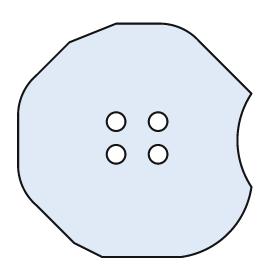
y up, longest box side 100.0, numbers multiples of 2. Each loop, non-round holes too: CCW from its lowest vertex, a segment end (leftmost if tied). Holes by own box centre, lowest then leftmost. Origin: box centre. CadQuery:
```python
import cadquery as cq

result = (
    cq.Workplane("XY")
    .moveTo(-14.0, -50.0)
    .lineTo(20.0, -50.0)
    .threePointArc((40.0, -40.0), (50.0, -20.0))
    .threePointArc((44.0, 0.0), (50.0, 20.0))
    .lineTo(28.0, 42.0)
    .threePointArc((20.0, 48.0), (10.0, 50.0))
    .lineTo(-8.0, 50.0)
    .lineTo(-28.0, 42.0)
    .lineTo(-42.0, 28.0)
    .threePointArc((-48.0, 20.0), (-50.0, 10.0))
    .lineTo(-50.0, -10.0)
    .threePointArc((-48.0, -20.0), (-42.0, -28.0))
    .lineTo(-26.0, -44.0)
    .close()
    .moveTo(-8.0, -6.0)
    .circle(4.0)
    .moveTo(10.0, -6.0)
    .circle(4.0)
    .moveTo(-8.0, 8.0)
    .circle(4.0)
    .moveTo(10.0, 8.0)
    .circle(4.0)
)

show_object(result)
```